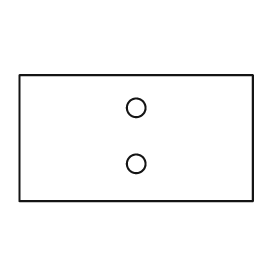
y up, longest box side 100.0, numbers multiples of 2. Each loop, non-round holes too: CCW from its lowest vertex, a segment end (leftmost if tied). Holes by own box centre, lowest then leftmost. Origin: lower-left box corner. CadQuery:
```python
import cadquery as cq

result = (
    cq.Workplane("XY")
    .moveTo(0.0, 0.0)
    .lineTo(100.0, 0.0)
    .lineTo(100.0, 54.0)
    .lineTo(0.0, 54.0)
    .close()
    .moveTo(50.0, 16.0)
    .circle(4.0)
    .moveTo(50.0, 40.0)
    .circle(4.0)
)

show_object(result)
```